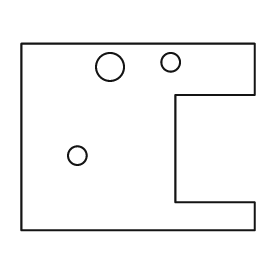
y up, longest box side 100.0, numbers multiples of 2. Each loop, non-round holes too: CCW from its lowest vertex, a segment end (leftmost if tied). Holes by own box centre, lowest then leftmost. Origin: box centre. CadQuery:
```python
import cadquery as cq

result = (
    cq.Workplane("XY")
    .moveTo(-50.0, -40.0)
    .lineTo(50.0, -40.0)
    .lineTo(50.0, -28.0)
    .lineTo(16.0, -28.0)
    .lineTo(16.0, 18.0)
    .lineTo(50.0, 18.0)
    .lineTo(50.0, 40.0)
    .lineTo(-50.0, 40.0)
    .close()
    .moveTo(-26.0, -8.0)
    .circle(4.0)
    .moveTo(-12.0, 30.0)
    .circle(6.0)
    .moveTo(14.0, 32.0)
    .circle(4.0)
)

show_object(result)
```